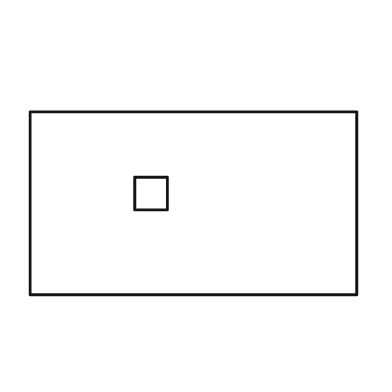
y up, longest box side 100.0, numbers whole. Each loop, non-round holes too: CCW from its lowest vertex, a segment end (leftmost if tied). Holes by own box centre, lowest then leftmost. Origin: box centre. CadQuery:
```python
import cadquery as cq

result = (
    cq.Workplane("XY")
    .moveTo(-50.0, -28.0)
    .lineTo(50.0, -28.0)
    .lineTo(50.0, 28.0)
    .lineTo(-50.0, 28.0)
    .close()
    .moveTo(-18.0, -2.0)
    .lineTo(-8.0, -2.0)
    .lineTo(-8.0, 8.0)
    .lineTo(-18.0, 8.0)
    .close()
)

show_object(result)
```